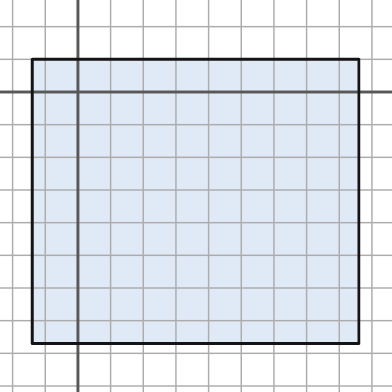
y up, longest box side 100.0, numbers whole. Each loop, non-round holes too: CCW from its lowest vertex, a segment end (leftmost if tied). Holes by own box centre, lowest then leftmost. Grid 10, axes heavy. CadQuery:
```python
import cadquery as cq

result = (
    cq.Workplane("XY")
    .moveTo(-14.0, -77.0)
    .lineTo(86.0, -77.0)
    .lineTo(86.0, 10.0)
    .lineTo(-14.0, 10.0)
    .close()
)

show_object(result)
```